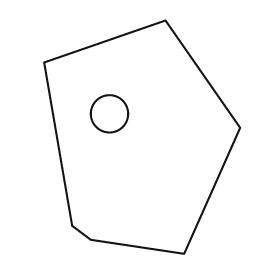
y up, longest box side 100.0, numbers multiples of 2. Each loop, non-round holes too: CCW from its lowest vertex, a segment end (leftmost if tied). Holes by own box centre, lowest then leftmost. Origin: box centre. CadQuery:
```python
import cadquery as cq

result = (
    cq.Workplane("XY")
    .moveTo(18.0, -50.0)
    .lineTo(42.0, 4.0)
    .lineTo(10.0, 50.0)
    .lineTo(-42.0, 32.0)
    .lineTo(-30.0, -38.0)
    .lineTo(-22.0, -44.0)
    .close()
    .moveTo(-14.0, 10.0)
    .circle(8.0)
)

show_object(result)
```